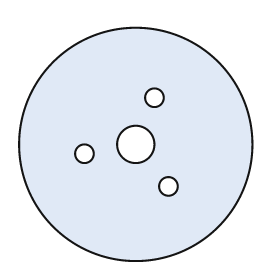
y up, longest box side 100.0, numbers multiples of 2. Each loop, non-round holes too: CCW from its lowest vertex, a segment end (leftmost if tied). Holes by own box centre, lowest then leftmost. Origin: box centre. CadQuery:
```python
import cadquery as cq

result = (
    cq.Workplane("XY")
    .moveTo(0.0, 0.0)
    .circle(50.0)
    .moveTo(14.0, -18.0)
    .circle(4.0)
    .moveTo(-22.0, -4.0)
    .circle(4.0)
    .moveTo(0.0, 0.0)
    .circle(8.0)
    .moveTo(8.0, 20.0)
    .circle(4.0)
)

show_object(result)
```